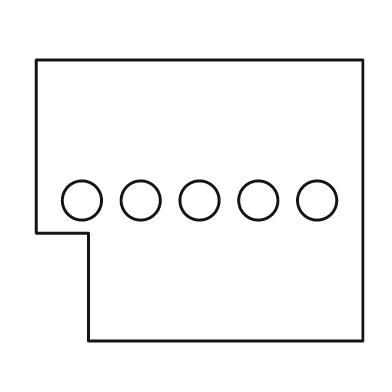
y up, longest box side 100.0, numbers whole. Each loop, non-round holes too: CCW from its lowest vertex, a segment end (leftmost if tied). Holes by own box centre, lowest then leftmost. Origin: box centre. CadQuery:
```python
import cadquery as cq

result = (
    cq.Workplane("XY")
    .moveTo(-34.0, -43.0)
    .lineTo(50.0, -43.0)
    .lineTo(50.0, 43.0)
    .lineTo(-50.0, 43.0)
    .lineTo(-50.0, -10.0)
    .lineTo(-34.0, -10.0)
    .close()
    .moveTo(-36.0, 0.0)
    .circle(6.0)
    .moveTo(-18.0, 0.0)
    .circle(6.0)
    .moveTo(0.0, 0.0)
    .circle(6.0)
    .moveTo(18.0, 0.0)
    .circle(6.0)
    .moveTo(36.0, 0.0)
    .circle(6.0)
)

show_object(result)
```